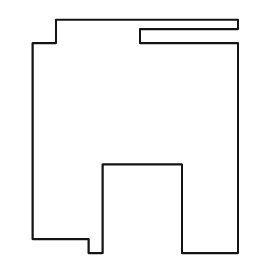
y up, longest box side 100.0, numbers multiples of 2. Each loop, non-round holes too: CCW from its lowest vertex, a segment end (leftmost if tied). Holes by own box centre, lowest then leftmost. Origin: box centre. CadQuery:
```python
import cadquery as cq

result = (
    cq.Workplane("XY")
    .moveTo(-20.0, -50.0)
    .lineTo(-14.0, -50.0)
    .lineTo(-14.0, -12.0)
    .lineTo(20.0, -12.0)
    .lineTo(20.0, -50.0)
    .lineTo(44.0, -50.0)
    .lineTo(44.0, 40.0)
    .lineTo(2.0, 40.0)
    .lineTo(2.0, 46.0)
    .lineTo(44.0, 46.0)
    .lineTo(44.0, 50.0)
    .lineTo(-34.0, 50.0)
    .lineTo(-34.0, 40.0)
    .lineTo(-44.0, 40.0)
    .lineTo(-44.0, -44.0)
    .lineTo(-20.0, -44.0)
    .close()
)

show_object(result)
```